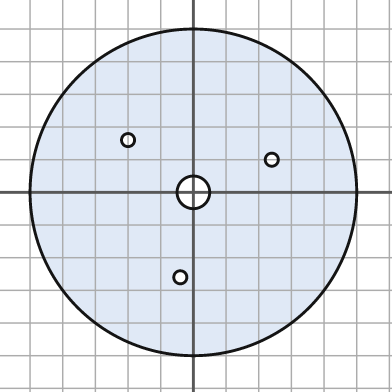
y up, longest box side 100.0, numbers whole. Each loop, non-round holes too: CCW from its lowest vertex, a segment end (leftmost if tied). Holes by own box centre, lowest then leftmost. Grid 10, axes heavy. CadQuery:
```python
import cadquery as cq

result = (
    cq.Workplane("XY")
    .moveTo(0.0, 0.0)
    .circle(50.0)
    .moveTo(-4.0, -26.0)
    .circle(2.0)
    .moveTo(0.0, 0.0)
    .circle(5.0)
    .moveTo(24.0, 10.0)
    .circle(2.0)
    .moveTo(-20.0, 16.0)
    .circle(2.0)
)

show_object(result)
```